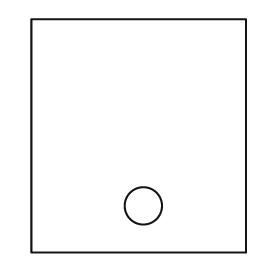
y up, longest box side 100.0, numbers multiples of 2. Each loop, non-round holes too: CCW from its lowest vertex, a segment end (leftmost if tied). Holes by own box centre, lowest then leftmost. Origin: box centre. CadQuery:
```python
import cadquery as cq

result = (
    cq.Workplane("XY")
    .moveTo(-46.0, -50.0)
    .lineTo(46.0, -50.0)
    .lineTo(46.0, 50.0)
    .lineTo(-46.0, 50.0)
    .close()
    .moveTo(2.0, -30.0)
    .circle(8.0)
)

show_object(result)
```